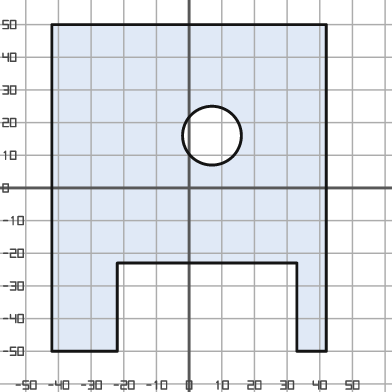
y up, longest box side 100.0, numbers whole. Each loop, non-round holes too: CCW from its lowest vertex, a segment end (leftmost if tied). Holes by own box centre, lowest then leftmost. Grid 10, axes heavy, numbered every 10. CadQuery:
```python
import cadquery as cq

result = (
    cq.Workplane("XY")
    .moveTo(-42.0, -50.0)
    .lineTo(-22.0, -50.0)
    .lineTo(-22.0, -23.0)
    .lineTo(33.0, -23.0)
    .lineTo(33.0, -50.0)
    .lineTo(42.0, -50.0)
    .lineTo(42.0, 50.0)
    .lineTo(-42.0, 50.0)
    .close()
    .moveTo(7.0, 16.0)
    .circle(9.0)
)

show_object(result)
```